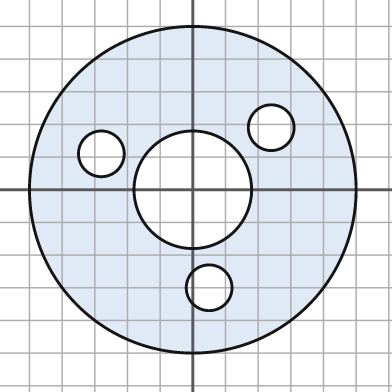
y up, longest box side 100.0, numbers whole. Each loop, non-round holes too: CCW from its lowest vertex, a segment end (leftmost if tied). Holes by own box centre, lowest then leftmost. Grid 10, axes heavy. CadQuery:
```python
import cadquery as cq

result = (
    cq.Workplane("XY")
    .moveTo(0.0, 0.0)
    .circle(50.0)
    .moveTo(5.0, -30.0)
    .circle(7.0)
    .moveTo(0.0, 0.0)
    .circle(18.0)
    .moveTo(-28.0, 11.0)
    .circle(7.0)
    .moveTo(24.0, 19.0)
    .circle(7.0)
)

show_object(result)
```